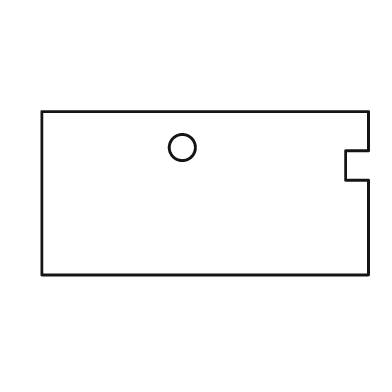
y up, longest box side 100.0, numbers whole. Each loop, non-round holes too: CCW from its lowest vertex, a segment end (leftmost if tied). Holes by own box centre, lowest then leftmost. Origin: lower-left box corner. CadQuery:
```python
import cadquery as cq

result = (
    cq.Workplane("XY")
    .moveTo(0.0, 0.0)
    .lineTo(100.0, 0.0)
    .lineTo(100.0, 29.0)
    .lineTo(93.0, 29.0)
    .lineTo(93.0, 38.0)
    .lineTo(100.0, 38.0)
    .lineTo(100.0, 50.0)
    .lineTo(0.0, 50.0)
    .close()
    .moveTo(43.0, 39.0)
    .circle(4.0)
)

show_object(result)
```